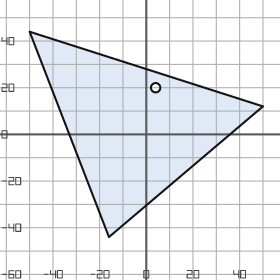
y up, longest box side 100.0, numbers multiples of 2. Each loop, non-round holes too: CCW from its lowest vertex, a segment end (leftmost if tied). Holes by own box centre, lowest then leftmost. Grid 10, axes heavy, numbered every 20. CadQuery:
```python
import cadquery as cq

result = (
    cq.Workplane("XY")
    .moveTo(-16.0, -44.0)
    .lineTo(50.0, 12.0)
    .lineTo(-50.0, 44.0)
    .close()
    .moveTo(4.0, 20.0)
    .circle(2.0)
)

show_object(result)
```